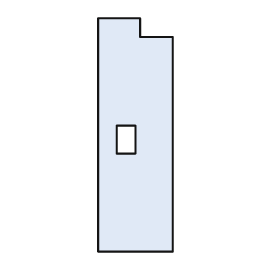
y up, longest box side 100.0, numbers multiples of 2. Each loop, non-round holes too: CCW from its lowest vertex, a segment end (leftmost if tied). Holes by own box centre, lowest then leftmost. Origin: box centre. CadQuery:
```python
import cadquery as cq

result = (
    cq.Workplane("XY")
    .moveTo(-16.0, -50.0)
    .lineTo(16.0, -50.0)
    .lineTo(16.0, 42.0)
    .lineTo(2.0, 42.0)
    .lineTo(2.0, 50.0)
    .lineTo(-16.0, 50.0)
    .close()
    .moveTo(-8.0, -8.0)
    .lineTo(0.0, -8.0)
    .lineTo(0.0, 4.0)
    .lineTo(-8.0, 4.0)
    .close()
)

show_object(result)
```